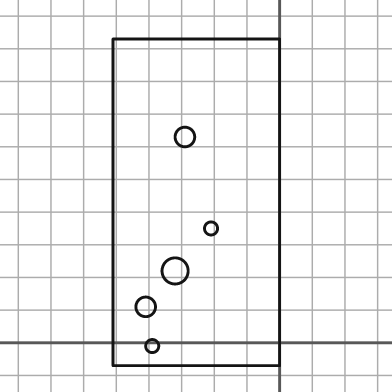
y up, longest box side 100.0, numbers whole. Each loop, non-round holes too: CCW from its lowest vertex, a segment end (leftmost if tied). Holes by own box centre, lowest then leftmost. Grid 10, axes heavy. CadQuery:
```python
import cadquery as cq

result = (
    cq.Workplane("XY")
    .moveTo(-51.0, -7.0)
    .lineTo(0.0, -7.0)
    .lineTo(0.0, 93.0)
    .lineTo(-51.0, 93.0)
    .close()
    .moveTo(-39.0, -1.0)
    .circle(2.0)
    .moveTo(-41.0, 11.0)
    .circle(3.0)
    .moveTo(-32.0, 22.0)
    .circle(4.0)
    .moveTo(-21.0, 35.0)
    .circle(2.0)
    .moveTo(-29.0, 63.0)
    .circle(3.0)
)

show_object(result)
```